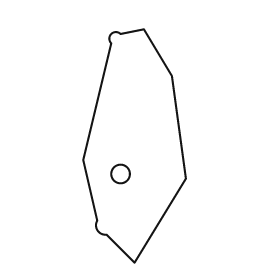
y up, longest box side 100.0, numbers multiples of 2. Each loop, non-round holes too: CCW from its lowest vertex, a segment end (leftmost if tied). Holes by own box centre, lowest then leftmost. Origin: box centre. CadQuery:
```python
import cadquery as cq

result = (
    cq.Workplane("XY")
    .moveTo(0.0, -50.0)
    .lineTo(22.0, -14.0)
    .lineTo(16.0, 30.0)
    .lineTo(4.0, 50.0)
    .lineTo(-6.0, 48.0)
    .threePointArc((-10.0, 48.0), (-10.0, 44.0))
    .lineTo(-22.0, -6.0)
    .lineTo(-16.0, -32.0)
    .threePointArc((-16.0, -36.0), (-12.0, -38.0))
    .close()
    .moveTo(-6.0, -12.0)
    .circle(4.0)
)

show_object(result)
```